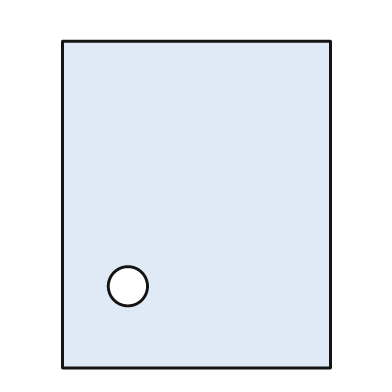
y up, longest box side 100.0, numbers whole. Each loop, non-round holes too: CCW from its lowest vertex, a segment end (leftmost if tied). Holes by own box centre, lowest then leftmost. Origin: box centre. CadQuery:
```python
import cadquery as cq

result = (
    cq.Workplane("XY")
    .moveTo(-41.0, -50.0)
    .lineTo(41.0, -50.0)
    .lineTo(41.0, 50.0)
    .lineTo(-41.0, 50.0)
    .close()
    .moveTo(-21.0, -25.0)
    .circle(6.0)
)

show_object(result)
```